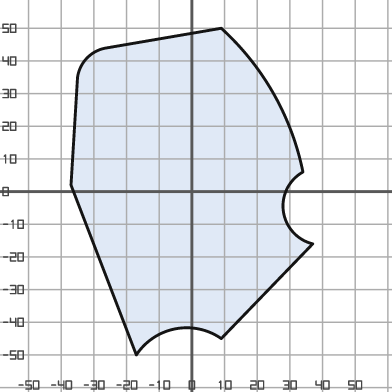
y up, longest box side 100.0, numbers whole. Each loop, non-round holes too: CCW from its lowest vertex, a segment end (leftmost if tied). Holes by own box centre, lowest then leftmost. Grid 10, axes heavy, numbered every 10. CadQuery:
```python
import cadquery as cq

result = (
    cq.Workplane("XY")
    .moveTo(-17.0, -50.0)
    .threePointArc((-5.0, -42.0), (9.0, -45.0))
    .lineTo(37.0, -16.0)
    .threePointArc((28.0, -6.0), (34.0, 6.0))
    .threePointArc((25.0, 30.0), (9.0, 50.0))
    .lineTo(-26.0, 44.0)
    .threePointArc((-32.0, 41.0), (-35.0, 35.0))
    .lineTo(-37.0, 2.0)
    .close()
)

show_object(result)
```